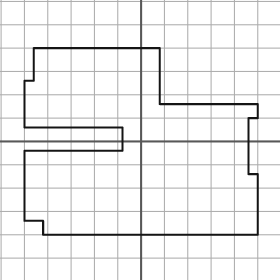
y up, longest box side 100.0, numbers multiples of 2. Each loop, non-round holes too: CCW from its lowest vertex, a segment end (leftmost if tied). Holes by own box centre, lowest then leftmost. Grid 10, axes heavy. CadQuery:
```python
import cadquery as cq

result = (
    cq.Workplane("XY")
    .moveTo(-42.0, -40.0)
    .lineTo(50.0, -40.0)
    .lineTo(50.0, -14.0)
    .lineTo(46.0, -14.0)
    .lineTo(46.0, 10.0)
    .lineTo(50.0, 10.0)
    .lineTo(50.0, 16.0)
    .lineTo(8.0, 16.0)
    .lineTo(8.0, 40.0)
    .lineTo(-46.0, 40.0)
    .lineTo(-46.0, 26.0)
    .lineTo(-50.0, 26.0)
    .lineTo(-50.0, 6.0)
    .lineTo(-8.0, 6.0)
    .lineTo(-8.0, -4.0)
    .lineTo(-50.0, -4.0)
    .lineTo(-50.0, -34.0)
    .lineTo(-42.0, -34.0)
    .close()
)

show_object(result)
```